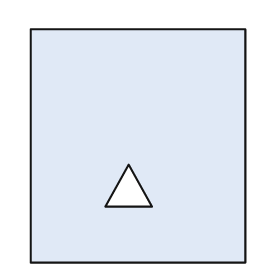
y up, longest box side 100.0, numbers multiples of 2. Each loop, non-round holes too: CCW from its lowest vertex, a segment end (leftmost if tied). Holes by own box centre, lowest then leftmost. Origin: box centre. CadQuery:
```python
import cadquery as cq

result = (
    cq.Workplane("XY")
    .moveTo(-46.0, -50.0)
    .lineTo(46.0, -50.0)
    .lineTo(46.0, 50.0)
    .lineTo(-46.0, 50.0)
    .close()
    .moveTo(-14.0, -26.0)
    .lineTo(6.0, -26.0)
    .lineTo(-4.0, -8.0)
    .close()
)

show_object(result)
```